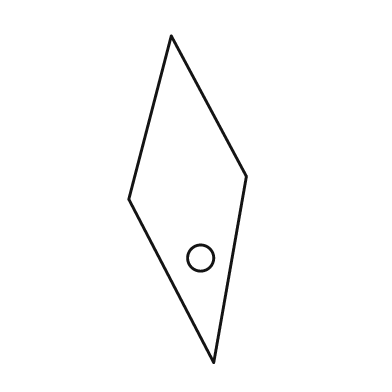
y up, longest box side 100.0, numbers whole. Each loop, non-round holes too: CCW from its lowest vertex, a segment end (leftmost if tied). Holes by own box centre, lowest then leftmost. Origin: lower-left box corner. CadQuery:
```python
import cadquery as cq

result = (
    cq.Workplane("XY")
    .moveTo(26.0, 0.0)
    .lineTo(36.0, 57.0)
    .lineTo(13.0, 100.0)
    .lineTo(0.0, 50.0)
    .close()
    .moveTo(22.0, 32.0)
    .circle(4.0)
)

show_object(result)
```